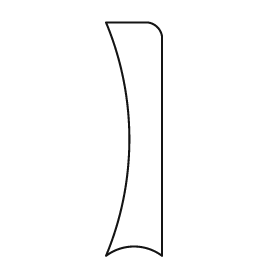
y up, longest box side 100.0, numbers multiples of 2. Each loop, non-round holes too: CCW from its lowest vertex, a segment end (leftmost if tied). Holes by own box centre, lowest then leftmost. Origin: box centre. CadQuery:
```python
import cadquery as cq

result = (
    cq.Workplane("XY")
    .moveTo(-12.0, -50.0)
    .threePointArc((0.0, -46.0), (12.0, -50.0))
    .lineTo(12.0, 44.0)
    .threePointArc((10.0, 48.0), (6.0, 50.0))
    .lineTo(-12.0, 50.0)
    .threePointArc((-2.0, 0.0), (-12.0, -50.0))
    .close()
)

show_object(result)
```